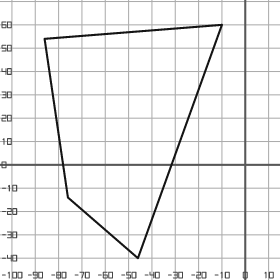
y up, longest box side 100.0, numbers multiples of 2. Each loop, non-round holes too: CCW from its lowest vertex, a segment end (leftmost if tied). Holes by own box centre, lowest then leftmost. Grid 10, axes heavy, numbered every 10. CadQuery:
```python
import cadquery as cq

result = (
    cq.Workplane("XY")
    .moveTo(-46.0, -40.0)
    .lineTo(-10.0, 60.0)
    .lineTo(-86.0, 54.0)
    .lineTo(-76.0, -14.0)
    .close()
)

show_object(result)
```